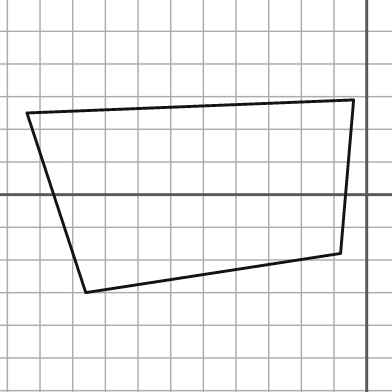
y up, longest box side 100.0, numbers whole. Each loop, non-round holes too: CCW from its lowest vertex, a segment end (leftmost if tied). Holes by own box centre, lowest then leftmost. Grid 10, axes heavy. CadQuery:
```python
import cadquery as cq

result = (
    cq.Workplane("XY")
    .moveTo(-86.0, -30.0)
    .lineTo(-8.0, -18.0)
    .lineTo(-4.0, 29.0)
    .lineTo(-104.0, 25.0)
    .close()
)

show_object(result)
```